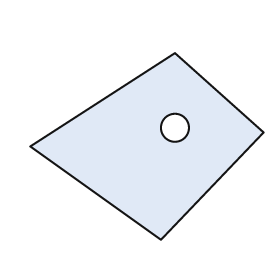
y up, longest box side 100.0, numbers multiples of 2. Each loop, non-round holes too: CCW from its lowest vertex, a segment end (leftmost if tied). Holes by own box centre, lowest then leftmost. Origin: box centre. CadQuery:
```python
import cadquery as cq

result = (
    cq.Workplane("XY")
    .moveTo(6.0, -40.0)
    .lineTo(50.0, 6.0)
    .lineTo(12.0, 40.0)
    .lineTo(-50.0, 0.0)
    .close()
    .moveTo(12.0, 8.0)
    .circle(6.0)
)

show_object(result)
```